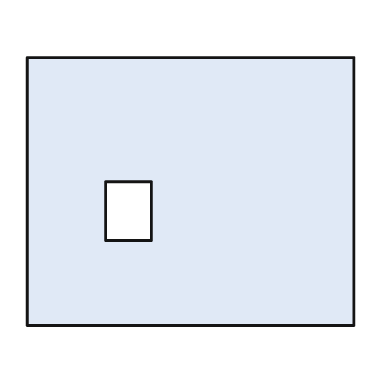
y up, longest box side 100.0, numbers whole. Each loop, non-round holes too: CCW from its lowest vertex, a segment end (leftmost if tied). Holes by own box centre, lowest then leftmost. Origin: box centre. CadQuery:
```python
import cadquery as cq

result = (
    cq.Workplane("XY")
    .moveTo(-50.0, -41.0)
    .lineTo(50.0, -41.0)
    .lineTo(50.0, 41.0)
    .lineTo(-50.0, 41.0)
    .close()
    .moveTo(-26.0, -15.0)
    .lineTo(-12.0, -15.0)
    .lineTo(-12.0, 3.0)
    .lineTo(-26.0, 3.0)
    .close()
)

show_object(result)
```